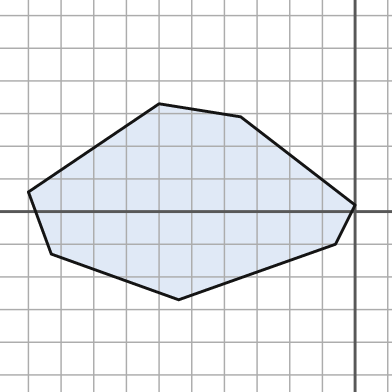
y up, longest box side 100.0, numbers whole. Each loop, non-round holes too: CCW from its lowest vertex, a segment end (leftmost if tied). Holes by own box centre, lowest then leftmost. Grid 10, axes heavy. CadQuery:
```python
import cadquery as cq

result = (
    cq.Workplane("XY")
    .moveTo(-54.0, -27.0)
    .lineTo(-6.0, -10.0)
    .lineTo(0.0, 2.0)
    .lineTo(-35.0, 29.0)
    .lineTo(-60.0, 33.0)
    .lineTo(-100.0, 6.0)
    .lineTo(-93.0, -13.0)
    .close()
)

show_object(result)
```